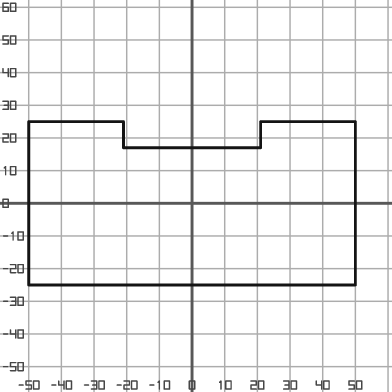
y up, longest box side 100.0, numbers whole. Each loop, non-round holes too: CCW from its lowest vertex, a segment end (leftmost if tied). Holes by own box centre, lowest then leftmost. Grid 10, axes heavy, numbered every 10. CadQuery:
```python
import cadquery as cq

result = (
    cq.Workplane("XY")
    .moveTo(-50.0, -25.0)
    .lineTo(50.0, -25.0)
    .lineTo(50.0, 25.0)
    .lineTo(21.0, 25.0)
    .lineTo(21.0, 17.0)
    .lineTo(-21.0, 17.0)
    .lineTo(-21.0, 25.0)
    .lineTo(-50.0, 25.0)
    .close()
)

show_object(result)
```